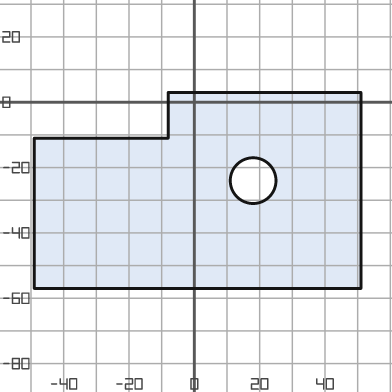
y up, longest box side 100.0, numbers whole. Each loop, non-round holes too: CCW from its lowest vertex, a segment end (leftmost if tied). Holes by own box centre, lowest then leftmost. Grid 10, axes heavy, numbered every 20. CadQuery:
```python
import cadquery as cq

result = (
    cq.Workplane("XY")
    .moveTo(-49.0, -57.0)
    .lineTo(51.0, -57.0)
    .lineTo(51.0, 3.0)
    .lineTo(-8.0, 3.0)
    .lineTo(-8.0, -11.0)
    .lineTo(-49.0, -11.0)
    .close()
    .moveTo(18.0, -24.0)
    .circle(7.0)
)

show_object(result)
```